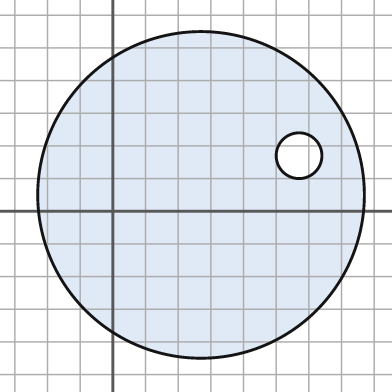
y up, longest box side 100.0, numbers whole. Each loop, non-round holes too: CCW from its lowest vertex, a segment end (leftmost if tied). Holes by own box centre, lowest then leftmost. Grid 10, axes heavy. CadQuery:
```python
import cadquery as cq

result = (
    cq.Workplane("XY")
    .moveTo(27.0, 5.0)
    .circle(50.0)
    .moveTo(57.0, 17.0)
    .circle(7.0)
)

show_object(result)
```